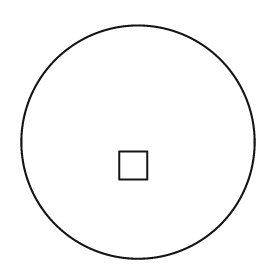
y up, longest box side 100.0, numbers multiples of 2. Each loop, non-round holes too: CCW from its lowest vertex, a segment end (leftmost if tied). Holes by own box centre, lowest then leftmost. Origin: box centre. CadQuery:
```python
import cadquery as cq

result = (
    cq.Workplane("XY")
    .moveTo(0.0, 0.0)
    .circle(50.0)
    .moveTo(-8.0, -16.0)
    .lineTo(4.0, -16.0)
    .lineTo(4.0, -4.0)
    .lineTo(-8.0, -4.0)
    .close()
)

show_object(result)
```